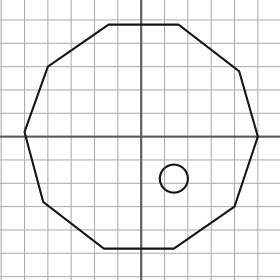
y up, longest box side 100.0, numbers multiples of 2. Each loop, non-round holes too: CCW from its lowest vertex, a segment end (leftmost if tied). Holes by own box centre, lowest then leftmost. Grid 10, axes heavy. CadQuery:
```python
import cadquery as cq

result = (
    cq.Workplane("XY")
    .moveTo(-16.0, -48.0)
    .lineTo(14.0, -48.0)
    .lineTo(40.0, -30.0)
    .lineTo(50.0, 0.0)
    .lineTo(42.0, 28.0)
    .lineTo(16.0, 48.0)
    .lineTo(-14.0, 48.0)
    .lineTo(-40.0, 30.0)
    .lineTo(-50.0, 2.0)
    .lineTo(-42.0, -28.0)
    .close()
    .moveTo(14.0, -18.0)
    .circle(6.0)
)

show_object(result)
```